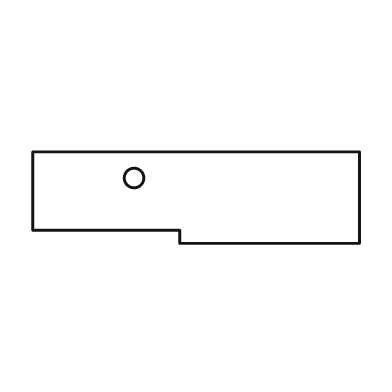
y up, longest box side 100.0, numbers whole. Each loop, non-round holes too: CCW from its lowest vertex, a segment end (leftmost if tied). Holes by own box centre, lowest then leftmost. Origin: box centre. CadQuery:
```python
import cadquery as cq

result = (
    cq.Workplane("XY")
    .moveTo(-5.0, -14.0)
    .lineTo(50.0, -14.0)
    .lineTo(50.0, 14.0)
    .lineTo(-50.0, 14.0)
    .lineTo(-50.0, -10.0)
    .lineTo(-5.0, -10.0)
    .close()
    .moveTo(-19.0, 6.0)
    .circle(3.0)
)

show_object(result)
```